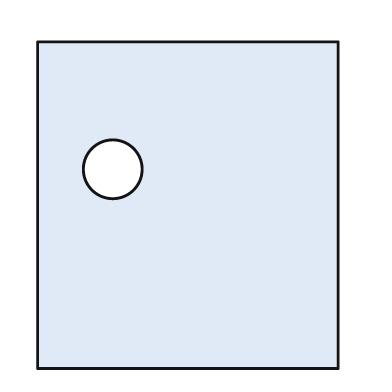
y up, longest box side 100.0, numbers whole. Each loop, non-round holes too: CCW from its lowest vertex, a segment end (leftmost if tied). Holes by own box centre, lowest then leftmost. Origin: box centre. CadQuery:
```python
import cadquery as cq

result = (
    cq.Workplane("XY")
    .moveTo(-46.0, -50.0)
    .lineTo(46.0, -50.0)
    .lineTo(46.0, 50.0)
    .lineTo(-46.0, 50.0)
    .close()
    .moveTo(-23.0, 11.0)
    .circle(9.0)
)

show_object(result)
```